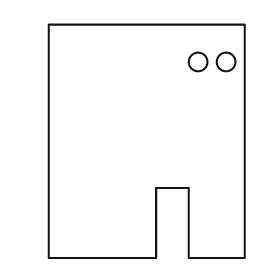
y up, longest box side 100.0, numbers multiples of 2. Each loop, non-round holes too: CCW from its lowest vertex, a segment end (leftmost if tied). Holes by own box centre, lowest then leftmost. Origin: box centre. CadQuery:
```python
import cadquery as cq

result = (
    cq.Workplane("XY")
    .moveTo(-42.0, -50.0)
    .lineTo(4.0, -50.0)
    .lineTo(4.0, -20.0)
    .lineTo(18.0, -20.0)
    .lineTo(18.0, -50.0)
    .lineTo(42.0, -50.0)
    .lineTo(42.0, 50.0)
    .lineTo(-42.0, 50.0)
    .close()
    .moveTo(22.0, 34.0)
    .circle(4.0)
    .moveTo(34.0, 34.0)
    .circle(4.0)
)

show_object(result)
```